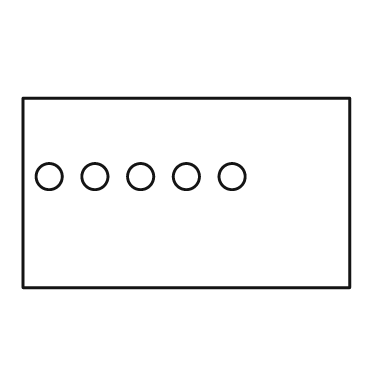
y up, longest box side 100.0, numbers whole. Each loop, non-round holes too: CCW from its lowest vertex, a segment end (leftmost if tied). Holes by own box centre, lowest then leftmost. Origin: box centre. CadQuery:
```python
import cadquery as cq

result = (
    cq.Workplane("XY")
    .moveTo(-50.0, -29.0)
    .lineTo(50.0, -29.0)
    .lineTo(50.0, 29.0)
    .lineTo(-50.0, 29.0)
    .close()
    .moveTo(-42.0, 5.0)
    .circle(4.0)
    .moveTo(-28.0, 5.0)
    .circle(4.0)
    .moveTo(-14.0, 5.0)
    .circle(4.0)
    .moveTo(0.0, 5.0)
    .circle(4.0)
    .moveTo(14.0, 5.0)
    .circle(4.0)
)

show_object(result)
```